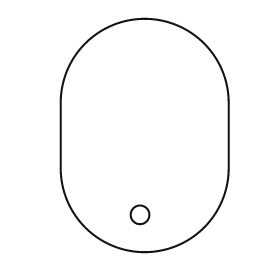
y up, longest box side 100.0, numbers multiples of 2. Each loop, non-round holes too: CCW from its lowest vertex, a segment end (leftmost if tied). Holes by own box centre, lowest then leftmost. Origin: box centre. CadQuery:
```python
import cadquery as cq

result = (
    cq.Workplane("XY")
    .moveTo(-36.0, -14.0)
    .threePointArc((0.0, -50.0), (36.0, -14.0))
    .lineTo(36.0, 14.0)
    .threePointArc((0.0, 50.0), (-36.0, 14.0))
    .close()
    .moveTo(-2.0, -34.0)
    .circle(4.0)
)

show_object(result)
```